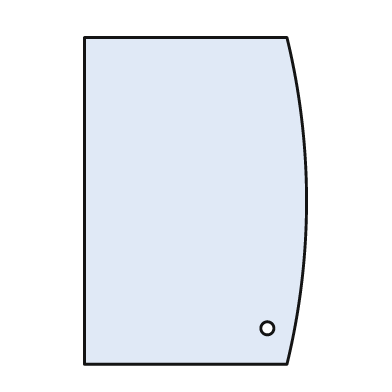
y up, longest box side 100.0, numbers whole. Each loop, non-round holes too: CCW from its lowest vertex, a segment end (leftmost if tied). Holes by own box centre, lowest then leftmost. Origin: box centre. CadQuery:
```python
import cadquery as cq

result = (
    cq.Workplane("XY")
    .moveTo(-34.0, -50.0)
    .lineTo(28.0, -50.0)
    .threePointArc((34.0, 0.0), (28.0, 50.0))
    .lineTo(-34.0, 50.0)
    .close()
    .moveTo(22.0, -39.0)
    .circle(2.0)
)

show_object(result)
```